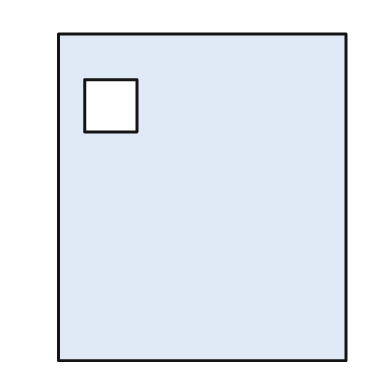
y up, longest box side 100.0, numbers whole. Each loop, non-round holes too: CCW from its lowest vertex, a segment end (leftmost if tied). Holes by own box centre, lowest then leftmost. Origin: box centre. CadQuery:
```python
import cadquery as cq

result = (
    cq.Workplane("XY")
    .moveTo(-44.0, -50.0)
    .lineTo(44.0, -50.0)
    .lineTo(44.0, 50.0)
    .lineTo(-44.0, 50.0)
    .close()
    .moveTo(-36.0, 20.0)
    .lineTo(-20.0, 20.0)
    .lineTo(-20.0, 36.0)
    .lineTo(-36.0, 36.0)
    .close()
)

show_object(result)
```